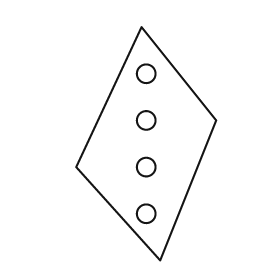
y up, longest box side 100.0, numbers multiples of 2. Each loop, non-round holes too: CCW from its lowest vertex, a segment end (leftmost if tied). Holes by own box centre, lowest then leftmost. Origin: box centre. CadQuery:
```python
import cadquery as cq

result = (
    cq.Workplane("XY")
    .moveTo(6.0, -50.0)
    .lineTo(30.0, 10.0)
    .lineTo(-2.0, 50.0)
    .lineTo(-30.0, -10.0)
    .close()
    .moveTo(0.0, -30.0)
    .circle(4.0)
    .moveTo(0.0, -10.0)
    .circle(4.0)
    .moveTo(0.0, 10.0)
    .circle(4.0)
    .moveTo(0.0, 30.0)
    .circle(4.0)
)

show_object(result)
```